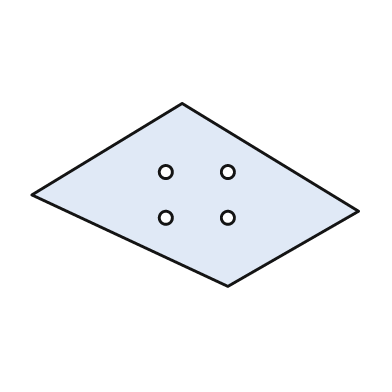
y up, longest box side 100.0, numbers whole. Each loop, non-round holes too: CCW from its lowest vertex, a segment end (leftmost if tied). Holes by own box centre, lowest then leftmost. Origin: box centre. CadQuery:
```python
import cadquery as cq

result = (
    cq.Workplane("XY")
    .moveTo(10.0, -28.0)
    .lineTo(50.0, -5.0)
    .lineTo(-4.0, 28.0)
    .lineTo(-50.0, 0.0)
    .close()
    .moveTo(-9.0, -7.0)
    .circle(2.0)
    .moveTo(10.0, -7.0)
    .circle(2.0)
    .moveTo(-9.0, 7.0)
    .circle(2.0)
    .moveTo(10.0, 7.0)
    .circle(2.0)
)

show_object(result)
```